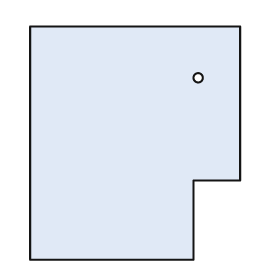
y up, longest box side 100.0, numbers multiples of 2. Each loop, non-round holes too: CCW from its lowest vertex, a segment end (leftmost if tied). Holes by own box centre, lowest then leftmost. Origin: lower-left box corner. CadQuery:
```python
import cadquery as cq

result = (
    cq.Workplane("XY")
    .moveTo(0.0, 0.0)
    .lineTo(70.0, 0.0)
    .lineTo(70.0, 34.0)
    .lineTo(90.0, 34.0)
    .lineTo(90.0, 100.0)
    .lineTo(0.0, 100.0)
    .close()
    .moveTo(72.0, 78.0)
    .circle(2.0)
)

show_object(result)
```